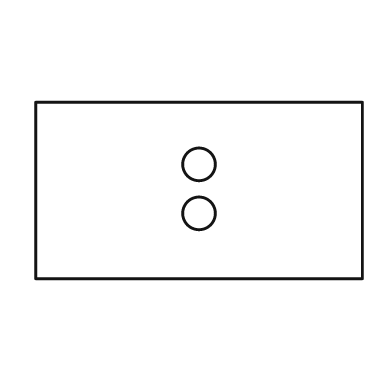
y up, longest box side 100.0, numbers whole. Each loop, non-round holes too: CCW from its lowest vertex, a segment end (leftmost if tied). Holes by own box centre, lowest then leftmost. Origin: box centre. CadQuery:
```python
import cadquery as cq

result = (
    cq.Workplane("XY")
    .moveTo(-50.0, -27.0)
    .lineTo(50.0, -27.0)
    .lineTo(50.0, 27.0)
    .lineTo(-50.0, 27.0)
    .close()
    .moveTo(0.0, -7.0)
    .circle(5.0)
    .moveTo(0.0, 8.0)
    .circle(5.0)
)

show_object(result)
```